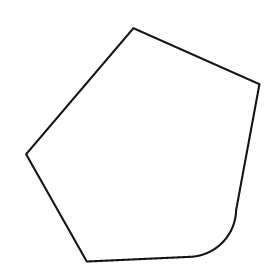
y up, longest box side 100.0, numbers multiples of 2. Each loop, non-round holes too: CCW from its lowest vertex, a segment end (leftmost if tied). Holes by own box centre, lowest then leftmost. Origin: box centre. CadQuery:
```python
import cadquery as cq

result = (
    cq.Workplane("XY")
    .moveTo(-24.0, -50.0)
    .lineTo(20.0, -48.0)
    .threePointArc((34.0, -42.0), (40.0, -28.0))
    .lineTo(50.0, 26.0)
    .lineTo(-4.0, 50.0)
    .lineTo(-50.0, -4.0)
    .close()
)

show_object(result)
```